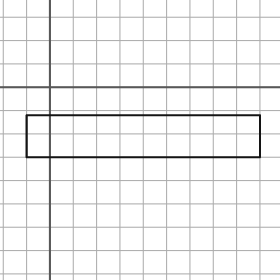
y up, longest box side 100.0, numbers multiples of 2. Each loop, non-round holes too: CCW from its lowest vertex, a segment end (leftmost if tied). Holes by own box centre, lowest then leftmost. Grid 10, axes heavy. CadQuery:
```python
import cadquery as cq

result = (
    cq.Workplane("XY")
    .moveTo(-10.0, -30.0)
    .lineTo(90.0, -30.0)
    .lineTo(90.0, -12.0)
    .lineTo(-10.0, -12.0)
    .close()
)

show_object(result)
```